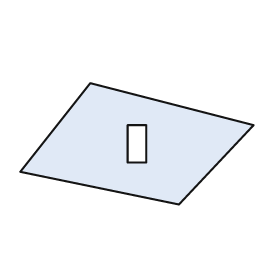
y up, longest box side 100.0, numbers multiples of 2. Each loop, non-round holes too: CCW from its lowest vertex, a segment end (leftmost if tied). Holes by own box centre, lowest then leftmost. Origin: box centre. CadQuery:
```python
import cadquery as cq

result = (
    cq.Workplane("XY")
    .moveTo(18.0, -26.0)
    .lineTo(50.0, 8.0)
    .lineTo(-20.0, 26.0)
    .lineTo(-50.0, -12.0)
    .close()
    .moveTo(-4.0, -8.0)
    .lineTo(4.0, -8.0)
    .lineTo(4.0, 8.0)
    .lineTo(-4.0, 8.0)
    .close()
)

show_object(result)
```